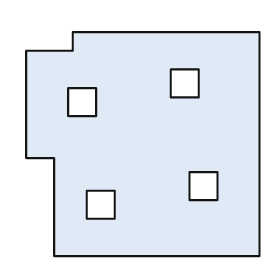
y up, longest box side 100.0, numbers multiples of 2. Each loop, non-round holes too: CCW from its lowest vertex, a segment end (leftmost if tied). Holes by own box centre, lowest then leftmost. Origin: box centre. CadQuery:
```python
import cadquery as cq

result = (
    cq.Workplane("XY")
    .moveTo(-38.0, -48.0)
    .lineTo(50.0, -48.0)
    .lineTo(50.0, 48.0)
    .lineTo(-30.0, 48.0)
    .lineTo(-30.0, 40.0)
    .lineTo(-50.0, 40.0)
    .lineTo(-50.0, -6.0)
    .lineTo(-38.0, -6.0)
    .close()
    .moveTo(-24.0, -32.0)
    .lineTo(-12.0, -32.0)
    .lineTo(-12.0, -20.0)
    .lineTo(-24.0, -20.0)
    .close()
    .moveTo(20.0, -24.0)
    .lineTo(32.0, -24.0)
    .lineTo(32.0, -12.0)
    .lineTo(20.0, -12.0)
    .close()
    .moveTo(-32.0, 12.0)
    .lineTo(-20.0, 12.0)
    .lineTo(-20.0, 24.0)
    .lineTo(-32.0, 24.0)
    .close()
    .moveTo(12.0, 20.0)
    .lineTo(24.0, 20.0)
    .lineTo(24.0, 32.0)
    .lineTo(12.0, 32.0)
    .close()
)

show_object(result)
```